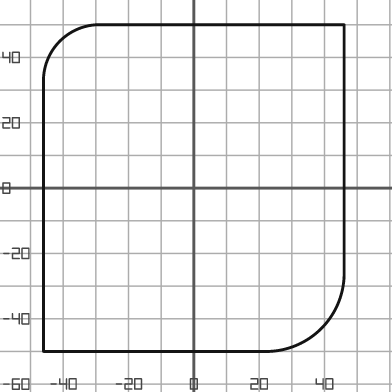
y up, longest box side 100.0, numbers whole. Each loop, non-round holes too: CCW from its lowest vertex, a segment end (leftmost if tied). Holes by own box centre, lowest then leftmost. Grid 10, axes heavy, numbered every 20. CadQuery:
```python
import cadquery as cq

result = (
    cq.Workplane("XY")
    .moveTo(-46.0, -50.0)
    .lineTo(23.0, -50.0)
    .threePointArc((39.0, -43.0), (46.0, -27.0))
    .lineTo(46.0, 50.0)
    .lineTo(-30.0, 50.0)
    .threePointArc((-41.0, 45.0), (-46.0, 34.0))
    .close()
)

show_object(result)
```